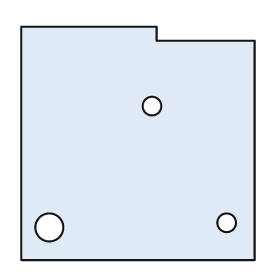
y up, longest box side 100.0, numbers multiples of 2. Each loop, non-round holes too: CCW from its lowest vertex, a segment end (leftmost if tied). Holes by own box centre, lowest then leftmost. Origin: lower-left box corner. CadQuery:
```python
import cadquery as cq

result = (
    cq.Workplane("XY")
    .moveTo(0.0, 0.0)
    .lineTo(100.0, 0.0)
    .lineTo(100.0, 94.0)
    .lineTo(58.0, 94.0)
    .lineTo(58.0, 100.0)
    .lineTo(0.0, 100.0)
    .close()
    .moveTo(12.0, 14.0)
    .circle(6.0)
    .moveTo(88.0, 16.0)
    .circle(4.0)
    .moveTo(56.0, 66.0)
    .circle(4.0)
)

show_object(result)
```